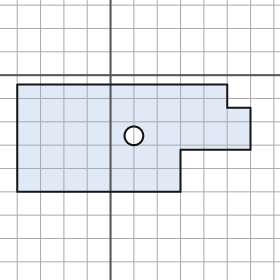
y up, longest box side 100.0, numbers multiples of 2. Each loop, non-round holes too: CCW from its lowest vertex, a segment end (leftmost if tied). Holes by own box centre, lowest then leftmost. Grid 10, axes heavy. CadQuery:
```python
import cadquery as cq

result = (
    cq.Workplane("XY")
    .moveTo(-40.0, -50.0)
    .lineTo(30.0, -50.0)
    .lineTo(30.0, -32.0)
    .lineTo(60.0, -32.0)
    .lineTo(60.0, -14.0)
    .lineTo(50.0, -14.0)
    .lineTo(50.0, -4.0)
    .lineTo(-40.0, -4.0)
    .close()
    .moveTo(10.0, -26.0)
    .circle(4.0)
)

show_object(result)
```